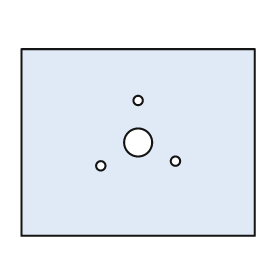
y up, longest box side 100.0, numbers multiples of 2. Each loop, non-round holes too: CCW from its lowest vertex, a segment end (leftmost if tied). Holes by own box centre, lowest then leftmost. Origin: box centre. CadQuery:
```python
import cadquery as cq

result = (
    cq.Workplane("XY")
    .moveTo(-50.0, -40.0)
    .lineTo(50.0, -40.0)
    .lineTo(50.0, 40.0)
    .lineTo(-50.0, 40.0)
    .close()
    .moveTo(-16.0, -10.0)
    .circle(2.0)
    .moveTo(16.0, -8.0)
    .circle(2.0)
    .moveTo(0.0, 0.0)
    .circle(6.0)
    .moveTo(0.0, 18.0)
    .circle(2.0)
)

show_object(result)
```